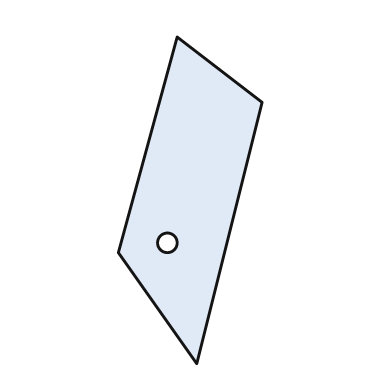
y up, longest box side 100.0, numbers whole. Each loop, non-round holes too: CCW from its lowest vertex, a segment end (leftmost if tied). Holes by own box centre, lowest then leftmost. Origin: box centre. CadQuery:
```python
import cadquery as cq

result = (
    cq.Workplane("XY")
    .moveTo(2.0, -50.0)
    .lineTo(22.0, 30.0)
    .lineTo(-4.0, 50.0)
    .lineTo(-22.0, -16.0)
    .close()
    .moveTo(-7.0, -13.0)
    .circle(3.0)
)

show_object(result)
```